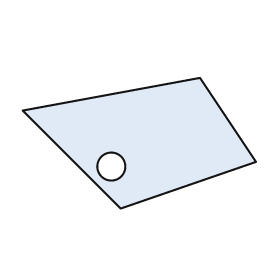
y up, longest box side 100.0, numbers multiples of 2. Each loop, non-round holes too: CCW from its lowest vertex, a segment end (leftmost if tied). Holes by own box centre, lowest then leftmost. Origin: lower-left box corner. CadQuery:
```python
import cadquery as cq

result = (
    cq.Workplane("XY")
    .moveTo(42.0, 0.0)
    .lineTo(100.0, 20.0)
    .lineTo(76.0, 56.0)
    .lineTo(0.0, 42.0)
    .close()
    .moveTo(38.0, 18.0)
    .circle(6.0)
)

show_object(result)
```